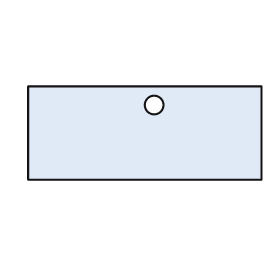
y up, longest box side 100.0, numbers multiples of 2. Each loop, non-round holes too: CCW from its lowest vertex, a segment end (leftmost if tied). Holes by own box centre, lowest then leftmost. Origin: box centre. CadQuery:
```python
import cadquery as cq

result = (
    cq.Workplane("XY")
    .moveTo(-50.0, -20.0)
    .lineTo(50.0, -20.0)
    .lineTo(50.0, 20.0)
    .lineTo(-50.0, 20.0)
    .close()
    .moveTo(4.0, 12.0)
    .circle(4.0)
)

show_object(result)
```